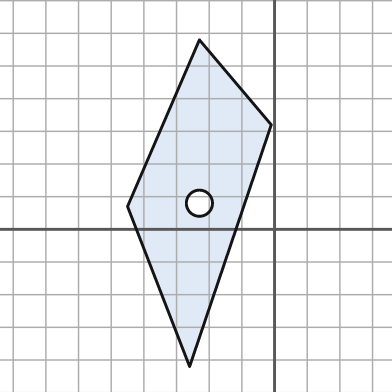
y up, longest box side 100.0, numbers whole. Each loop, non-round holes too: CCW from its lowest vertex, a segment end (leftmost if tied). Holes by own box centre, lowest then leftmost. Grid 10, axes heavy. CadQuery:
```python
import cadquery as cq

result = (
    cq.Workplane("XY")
    .moveTo(-26.0, -42.0)
    .lineTo(-1.0, 32.0)
    .lineTo(-23.0, 58.0)
    .lineTo(-45.0, 7.0)
    .close()
    .moveTo(-23.0, 8.0)
    .circle(4.0)
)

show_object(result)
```